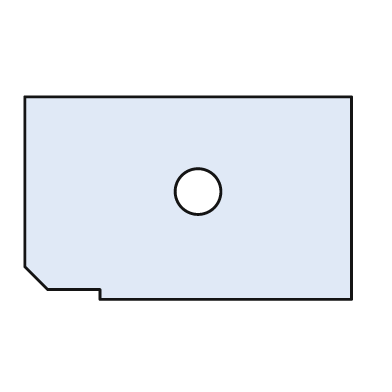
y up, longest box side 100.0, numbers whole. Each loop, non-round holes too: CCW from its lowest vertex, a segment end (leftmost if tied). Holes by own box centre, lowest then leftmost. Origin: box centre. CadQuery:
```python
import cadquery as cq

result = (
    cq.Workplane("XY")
    .moveTo(-27.0, -31.0)
    .lineTo(50.0, -31.0)
    .lineTo(50.0, 31.0)
    .lineTo(-50.0, 31.0)
    .lineTo(-50.0, -21.0)
    .lineTo(-43.0, -28.0)
    .lineTo(-27.0, -28.0)
    .close()
    .moveTo(3.0, 2.0)
    .circle(7.0)
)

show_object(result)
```